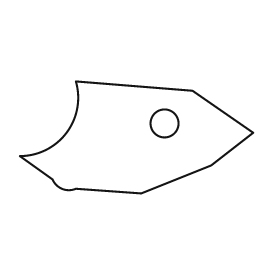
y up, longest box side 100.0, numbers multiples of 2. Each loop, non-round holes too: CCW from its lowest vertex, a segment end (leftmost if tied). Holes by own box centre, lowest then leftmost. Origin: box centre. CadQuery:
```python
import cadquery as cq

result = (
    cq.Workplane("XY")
    .moveTo(2.0, -24.0)
    .lineTo(32.0, -12.0)
    .lineTo(50.0, 2.0)
    .lineTo(24.0, 20.0)
    .lineTo(-26.0, 24.0)
    .threePointArc((-30.0, 2.0), (-50.0, -8.0))
    .lineTo(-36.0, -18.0)
    .threePointArc((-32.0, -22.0), (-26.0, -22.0))
    .close()
    .moveTo(12.0, 6.0)
    .circle(6.0)
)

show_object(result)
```